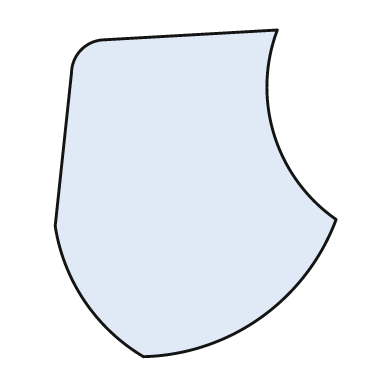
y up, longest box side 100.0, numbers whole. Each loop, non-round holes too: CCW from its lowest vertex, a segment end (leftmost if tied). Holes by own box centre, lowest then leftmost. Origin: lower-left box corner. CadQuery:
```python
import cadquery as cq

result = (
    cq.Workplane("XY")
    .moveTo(27.0, 0.0)
    .threePointArc((63.0, 12.0), (86.0, 42.0))
    .threePointArc((67.0, 68.0), (68.0, 100.0))
    .lineTo(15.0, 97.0)
    .threePointArc((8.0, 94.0), (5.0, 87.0))
    .lineTo(0.0, 40.0)
    .threePointArc((9.0, 17.0), (27.0, 0.0))
    .close()
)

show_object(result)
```